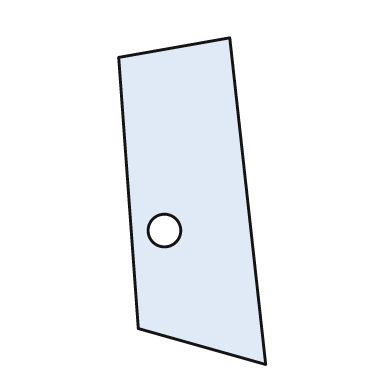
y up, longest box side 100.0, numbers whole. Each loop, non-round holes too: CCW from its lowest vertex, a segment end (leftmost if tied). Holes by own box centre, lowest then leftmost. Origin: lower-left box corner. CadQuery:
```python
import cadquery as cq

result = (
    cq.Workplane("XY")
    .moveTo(45.0, 0.0)
    .lineTo(34.0, 100.0)
    .lineTo(0.0, 94.0)
    .lineTo(6.0, 11.0)
    .close()
    .moveTo(14.0, 41.0)
    .circle(5.0)
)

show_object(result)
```